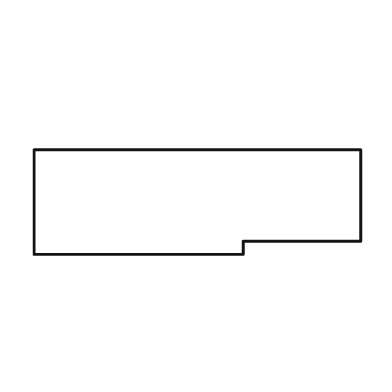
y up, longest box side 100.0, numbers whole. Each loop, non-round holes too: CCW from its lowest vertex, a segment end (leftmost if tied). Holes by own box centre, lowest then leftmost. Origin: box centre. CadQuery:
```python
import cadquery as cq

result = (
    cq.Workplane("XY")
    .moveTo(-50.0, -16.0)
    .lineTo(14.0, -16.0)
    .lineTo(14.0, -12.0)
    .lineTo(50.0, -12.0)
    .lineTo(50.0, 16.0)
    .lineTo(-50.0, 16.0)
    .close()
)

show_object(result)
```